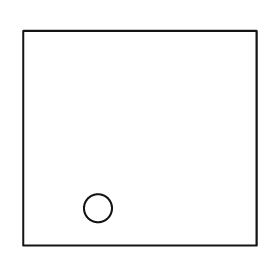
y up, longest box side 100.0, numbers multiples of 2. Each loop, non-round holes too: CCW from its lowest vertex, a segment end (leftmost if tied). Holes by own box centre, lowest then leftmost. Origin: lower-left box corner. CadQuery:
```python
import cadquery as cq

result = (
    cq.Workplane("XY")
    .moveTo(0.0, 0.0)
    .lineTo(100.0, 0.0)
    .lineTo(100.0, 92.0)
    .lineTo(0.0, 92.0)
    .close()
    .moveTo(32.0, 16.0)
    .circle(6.0)
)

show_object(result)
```